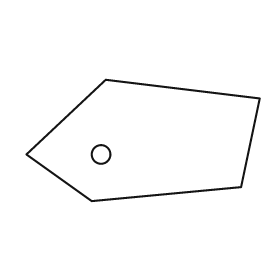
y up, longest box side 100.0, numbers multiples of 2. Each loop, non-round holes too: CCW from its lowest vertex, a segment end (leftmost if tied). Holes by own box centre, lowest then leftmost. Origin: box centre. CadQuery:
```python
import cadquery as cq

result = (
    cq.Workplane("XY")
    .moveTo(-22.0, -26.0)
    .lineTo(42.0, -20.0)
    .lineTo(50.0, 18.0)
    .lineTo(-16.0, 26.0)
    .lineTo(-50.0, -6.0)
    .close()
    .moveTo(-18.0, -6.0)
    .circle(4.0)
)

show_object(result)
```